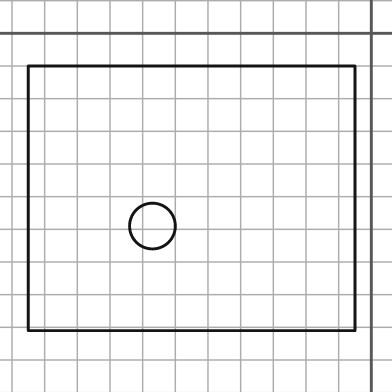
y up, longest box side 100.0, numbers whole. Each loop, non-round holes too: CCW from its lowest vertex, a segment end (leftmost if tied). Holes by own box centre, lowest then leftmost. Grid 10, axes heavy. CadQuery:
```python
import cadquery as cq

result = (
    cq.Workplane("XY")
    .moveTo(-105.0, -91.0)
    .lineTo(-5.0, -91.0)
    .lineTo(-5.0, -10.0)
    .lineTo(-105.0, -10.0)
    .close()
    .moveTo(-67.0, -59.0)
    .circle(7.0)
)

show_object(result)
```